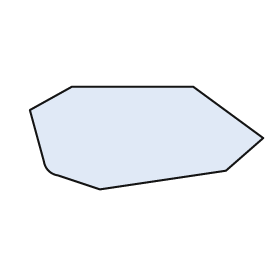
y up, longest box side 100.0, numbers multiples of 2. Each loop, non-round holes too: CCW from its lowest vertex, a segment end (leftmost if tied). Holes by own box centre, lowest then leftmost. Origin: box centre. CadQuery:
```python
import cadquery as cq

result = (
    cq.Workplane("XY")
    .moveTo(-20.0, -22.0)
    .lineTo(34.0, -14.0)
    .lineTo(50.0, 0.0)
    .lineTo(20.0, 22.0)
    .lineTo(-32.0, 22.0)
    .lineTo(-50.0, 12.0)
    .lineTo(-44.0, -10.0)
    .threePointArc((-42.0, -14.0), (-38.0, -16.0))
    .close()
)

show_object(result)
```